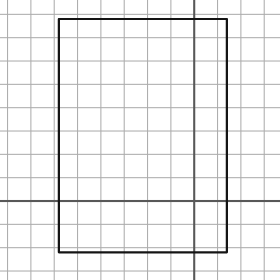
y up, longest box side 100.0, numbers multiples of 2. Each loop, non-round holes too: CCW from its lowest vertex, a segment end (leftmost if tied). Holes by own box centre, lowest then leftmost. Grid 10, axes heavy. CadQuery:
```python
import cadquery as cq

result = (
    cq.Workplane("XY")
    .moveTo(-58.0, -22.0)
    .lineTo(14.0, -22.0)
    .lineTo(14.0, 78.0)
    .lineTo(-58.0, 78.0)
    .close()
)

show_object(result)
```